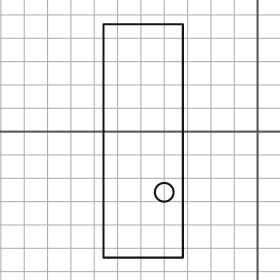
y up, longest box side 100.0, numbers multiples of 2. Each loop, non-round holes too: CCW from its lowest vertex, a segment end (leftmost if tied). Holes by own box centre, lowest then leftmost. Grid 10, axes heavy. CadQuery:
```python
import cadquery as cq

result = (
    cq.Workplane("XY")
    .moveTo(-66.0, -54.0)
    .lineTo(-32.0, -54.0)
    .lineTo(-32.0, 46.0)
    .lineTo(-66.0, 46.0)
    .close()
    .moveTo(-40.0, -26.0)
    .circle(4.0)
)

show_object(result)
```